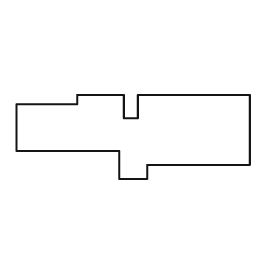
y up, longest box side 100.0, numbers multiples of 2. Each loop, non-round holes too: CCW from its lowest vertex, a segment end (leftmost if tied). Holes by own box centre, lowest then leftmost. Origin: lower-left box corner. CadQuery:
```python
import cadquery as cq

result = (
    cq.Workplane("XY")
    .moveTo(44.0, 0.0)
    .lineTo(56.0, 0.0)
    .lineTo(56.0, 6.0)
    .lineTo(100.0, 6.0)
    .lineTo(100.0, 36.0)
    .lineTo(52.0, 36.0)
    .lineTo(52.0, 26.0)
    .lineTo(46.0, 26.0)
    .lineTo(46.0, 36.0)
    .lineTo(26.0, 36.0)
    .lineTo(26.0, 32.0)
    .lineTo(0.0, 32.0)
    .lineTo(0.0, 12.0)
    .lineTo(44.0, 12.0)
    .close()
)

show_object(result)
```